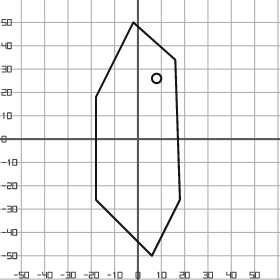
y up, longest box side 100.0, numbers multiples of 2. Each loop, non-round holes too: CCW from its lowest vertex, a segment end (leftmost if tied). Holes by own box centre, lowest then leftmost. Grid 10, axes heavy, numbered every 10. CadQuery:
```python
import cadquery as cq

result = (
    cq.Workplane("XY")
    .moveTo(6.0, -50.0)
    .lineTo(18.0, -26.0)
    .lineTo(16.0, 34.0)
    .lineTo(-2.0, 50.0)
    .lineTo(-18.0, 18.0)
    .lineTo(-18.0, -26.0)
    .close()
    .moveTo(8.0, 26.0)
    .circle(2.0)
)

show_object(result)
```